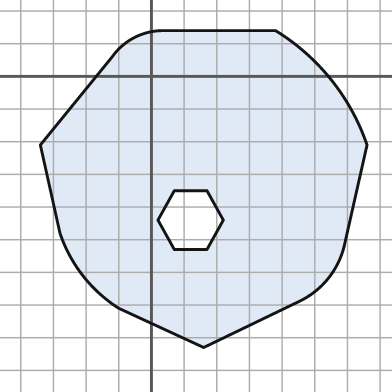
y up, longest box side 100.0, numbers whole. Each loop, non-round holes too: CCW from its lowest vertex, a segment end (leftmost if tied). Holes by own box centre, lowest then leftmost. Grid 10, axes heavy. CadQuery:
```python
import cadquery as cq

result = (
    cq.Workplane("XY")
    .moveTo(16.0, -83.0)
    .lineTo(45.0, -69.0)
    .threePointArc((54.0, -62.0), (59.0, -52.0))
    .lineTo(66.0, -21.0)
    .threePointArc((55.0, -1.0), (38.0, 14.0))
    .lineTo(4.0, 14.0)
    .threePointArc((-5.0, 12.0), (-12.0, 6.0))
    .lineTo(-34.0, -21.0)
    .lineTo(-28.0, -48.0)
    .threePointArc((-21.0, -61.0), (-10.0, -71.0))
    .close()
    .moveTo(7.0, -53.0)
    .lineTo(17.0, -53.0)
    .lineTo(22.0, -44.0)
    .lineTo(17.0, -35.0)
    .lineTo(7.0, -35.0)
    .lineTo(2.0, -44.0)
    .close()
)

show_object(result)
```